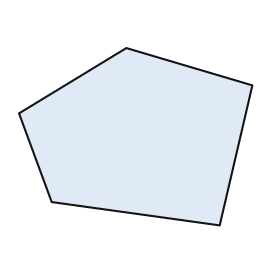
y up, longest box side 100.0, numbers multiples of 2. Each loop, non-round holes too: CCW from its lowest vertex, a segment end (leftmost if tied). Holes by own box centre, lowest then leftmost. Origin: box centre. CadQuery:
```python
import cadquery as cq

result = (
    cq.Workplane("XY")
    .moveTo(36.0, -38.0)
    .lineTo(50.0, 22.0)
    .lineTo(-4.0, 38.0)
    .lineTo(-50.0, 10.0)
    .lineTo(-36.0, -28.0)
    .close()
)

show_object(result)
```